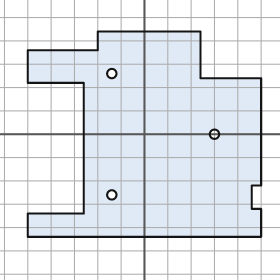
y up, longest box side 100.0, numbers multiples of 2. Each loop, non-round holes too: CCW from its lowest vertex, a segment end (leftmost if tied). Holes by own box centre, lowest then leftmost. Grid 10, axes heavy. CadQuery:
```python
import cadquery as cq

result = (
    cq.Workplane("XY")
    .moveTo(-50.0, -44.0)
    .lineTo(50.0, -44.0)
    .lineTo(50.0, -32.0)
    .lineTo(46.0, -32.0)
    .lineTo(46.0, -22.0)
    .lineTo(50.0, -22.0)
    .lineTo(50.0, 24.0)
    .lineTo(24.0, 24.0)
    .lineTo(24.0, 44.0)
    .lineTo(-20.0, 44.0)
    .lineTo(-20.0, 36.0)
    .lineTo(-50.0, 36.0)
    .lineTo(-50.0, 22.0)
    .lineTo(-26.0, 22.0)
    .lineTo(-26.0, -34.0)
    .lineTo(-50.0, -34.0)
    .close()
    .moveTo(-14.0, -26.0)
    .circle(2.0)
    .moveTo(30.0, 0.0)
    .circle(2.0)
    .moveTo(-14.0, 26.0)
    .circle(2.0)
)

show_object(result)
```